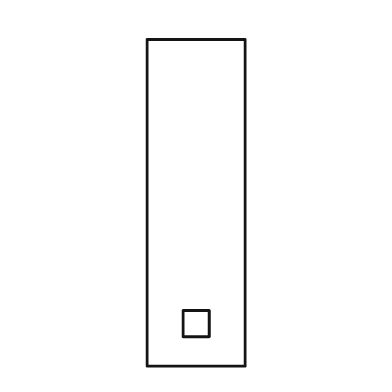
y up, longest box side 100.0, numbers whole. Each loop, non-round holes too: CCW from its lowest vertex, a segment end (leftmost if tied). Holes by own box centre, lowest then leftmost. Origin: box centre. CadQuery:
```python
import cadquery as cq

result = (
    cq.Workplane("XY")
    .moveTo(-15.0, -50.0)
    .lineTo(15.0, -50.0)
    .lineTo(15.0, 50.0)
    .lineTo(-15.0, 50.0)
    .close()
    .moveTo(-4.0, -41.0)
    .lineTo(4.0, -41.0)
    .lineTo(4.0, -33.0)
    .lineTo(-4.0, -33.0)
    .close()
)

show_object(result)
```